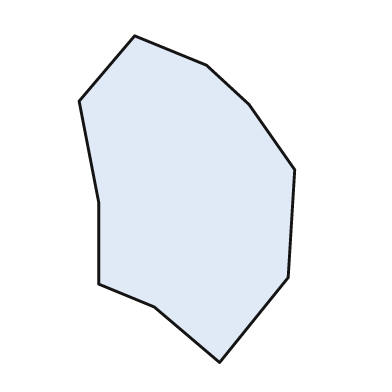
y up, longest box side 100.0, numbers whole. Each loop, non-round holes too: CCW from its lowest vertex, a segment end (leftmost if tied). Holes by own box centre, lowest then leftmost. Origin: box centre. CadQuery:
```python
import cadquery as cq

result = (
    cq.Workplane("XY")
    .moveTo(10.0, -50.0)
    .lineTo(31.0, -24.0)
    .lineTo(33.0, 9.0)
    .lineTo(19.0, 29.0)
    .lineTo(6.0, 41.0)
    .lineTo(-16.0, 50.0)
    .lineTo(-33.0, 30.0)
    .lineTo(-27.0, -1.0)
    .lineTo(-27.0, -26.0)
    .lineTo(-10.0, -33.0)
    .close()
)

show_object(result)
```